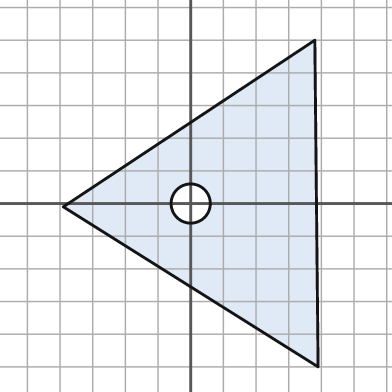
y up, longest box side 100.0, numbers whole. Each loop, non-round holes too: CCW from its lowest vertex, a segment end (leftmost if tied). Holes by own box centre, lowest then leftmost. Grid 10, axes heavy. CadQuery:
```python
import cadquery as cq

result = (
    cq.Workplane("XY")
    .moveTo(39.0, -50.0)
    .lineTo(38.0, 50.0)
    .lineTo(-39.0, -1.0)
    .close()
    .moveTo(0.0, 0.0)
    .circle(6.0)
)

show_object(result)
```